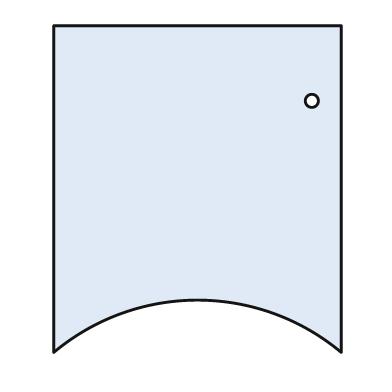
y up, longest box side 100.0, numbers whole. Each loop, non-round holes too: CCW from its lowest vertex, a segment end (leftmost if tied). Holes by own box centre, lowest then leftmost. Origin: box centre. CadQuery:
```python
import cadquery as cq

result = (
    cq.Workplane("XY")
    .moveTo(-44.0, -50.0)
    .threePointArc((0.0, -34.0), (44.0, -50.0))
    .lineTo(44.0, 50.0)
    .lineTo(-44.0, 50.0)
    .close()
    .moveTo(35.0, 27.0)
    .circle(2.0)
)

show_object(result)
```